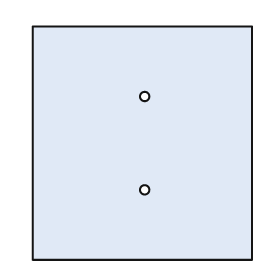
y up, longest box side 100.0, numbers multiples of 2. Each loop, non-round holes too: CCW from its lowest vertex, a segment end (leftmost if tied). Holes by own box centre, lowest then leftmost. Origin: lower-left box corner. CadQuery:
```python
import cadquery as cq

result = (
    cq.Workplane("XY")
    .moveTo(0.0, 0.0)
    .lineTo(94.0, 0.0)
    .lineTo(94.0, 100.0)
    .lineTo(0.0, 100.0)
    .close()
    .moveTo(48.0, 30.0)
    .circle(2.0)
    .moveTo(48.0, 70.0)
    .circle(2.0)
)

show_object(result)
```